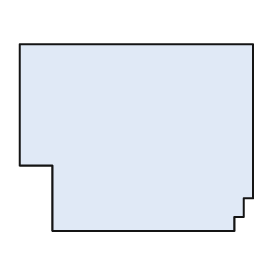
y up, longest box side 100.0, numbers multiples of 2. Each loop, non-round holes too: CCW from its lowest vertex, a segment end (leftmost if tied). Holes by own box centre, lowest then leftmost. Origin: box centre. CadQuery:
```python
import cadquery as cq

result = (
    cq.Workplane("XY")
    .moveTo(-36.0, -40.0)
    .lineTo(42.0, -40.0)
    .lineTo(42.0, -34.0)
    .lineTo(46.0, -34.0)
    .lineTo(46.0, -26.0)
    .lineTo(50.0, -26.0)
    .lineTo(50.0, 40.0)
    .lineTo(-50.0, 40.0)
    .lineTo(-50.0, -12.0)
    .lineTo(-36.0, -12.0)
    .close()
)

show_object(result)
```